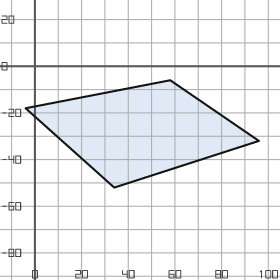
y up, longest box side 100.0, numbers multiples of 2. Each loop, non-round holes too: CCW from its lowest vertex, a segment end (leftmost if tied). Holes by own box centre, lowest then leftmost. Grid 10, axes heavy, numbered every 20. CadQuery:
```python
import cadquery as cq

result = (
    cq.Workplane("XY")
    .moveTo(34.0, -52.0)
    .lineTo(96.0, -32.0)
    .lineTo(58.0, -6.0)
    .lineTo(-4.0, -18.0)
    .close()
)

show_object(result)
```